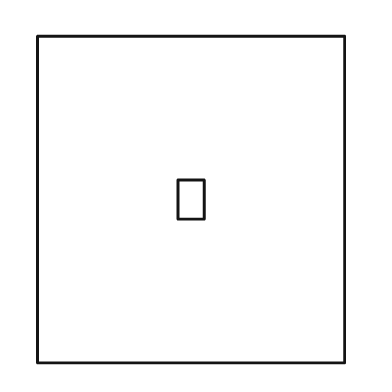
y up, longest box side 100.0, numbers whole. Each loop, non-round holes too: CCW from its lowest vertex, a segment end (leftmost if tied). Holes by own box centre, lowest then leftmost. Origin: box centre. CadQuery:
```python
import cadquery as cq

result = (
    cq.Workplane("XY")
    .moveTo(-47.0, -50.0)
    .lineTo(47.0, -50.0)
    .lineTo(47.0, 50.0)
    .lineTo(-47.0, 50.0)
    .close()
    .moveTo(-4.0, -6.0)
    .lineTo(4.0, -6.0)
    .lineTo(4.0, 6.0)
    .lineTo(-4.0, 6.0)
    .close()
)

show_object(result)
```